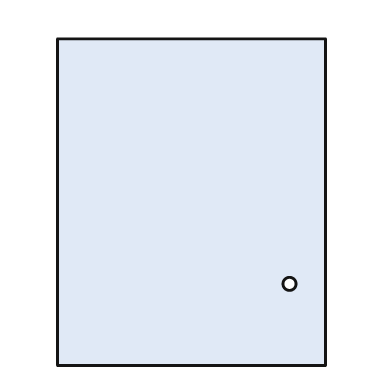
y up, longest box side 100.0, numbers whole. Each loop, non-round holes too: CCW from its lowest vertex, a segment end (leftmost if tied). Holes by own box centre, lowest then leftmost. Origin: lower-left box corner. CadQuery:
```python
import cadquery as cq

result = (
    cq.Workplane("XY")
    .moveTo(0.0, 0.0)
    .lineTo(82.0, 0.0)
    .lineTo(82.0, 100.0)
    .lineTo(0.0, 100.0)
    .close()
    .moveTo(71.0, 25.0)
    .circle(2.0)
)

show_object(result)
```